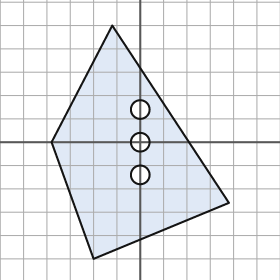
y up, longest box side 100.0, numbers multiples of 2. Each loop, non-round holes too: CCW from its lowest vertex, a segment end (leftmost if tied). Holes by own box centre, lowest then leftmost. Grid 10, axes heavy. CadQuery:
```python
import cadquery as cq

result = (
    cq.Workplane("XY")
    .moveTo(-20.0, -50.0)
    .lineTo(38.0, -26.0)
    .lineTo(-12.0, 50.0)
    .lineTo(-38.0, 0.0)
    .close()
    .moveTo(0.0, -14.0)
    .circle(4.0)
    .moveTo(0.0, 0.0)
    .circle(4.0)
    .moveTo(0.0, 14.0)
    .circle(4.0)
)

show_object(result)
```